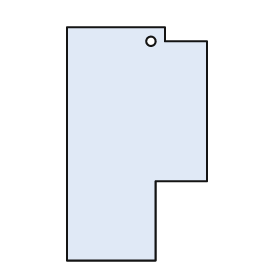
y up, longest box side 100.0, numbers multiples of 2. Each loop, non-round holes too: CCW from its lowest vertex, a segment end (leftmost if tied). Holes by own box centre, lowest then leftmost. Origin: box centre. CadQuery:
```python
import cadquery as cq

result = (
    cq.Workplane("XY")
    .moveTo(-30.0, -50.0)
    .lineTo(8.0, -50.0)
    .lineTo(8.0, -16.0)
    .lineTo(30.0, -16.0)
    .lineTo(30.0, 44.0)
    .lineTo(12.0, 44.0)
    .lineTo(12.0, 50.0)
    .lineTo(-30.0, 50.0)
    .close()
    .moveTo(6.0, 44.0)
    .circle(2.0)
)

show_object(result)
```